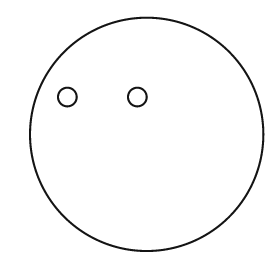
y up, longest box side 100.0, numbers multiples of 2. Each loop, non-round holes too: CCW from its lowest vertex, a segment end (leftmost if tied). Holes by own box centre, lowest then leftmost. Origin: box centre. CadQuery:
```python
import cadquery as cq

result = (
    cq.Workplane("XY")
    .moveTo(0.0, 0.0)
    .circle(50.0)
    .moveTo(-34.0, 16.0)
    .circle(4.0)
    .moveTo(-4.0, 16.0)
    .circle(4.0)
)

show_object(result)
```